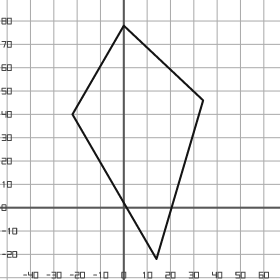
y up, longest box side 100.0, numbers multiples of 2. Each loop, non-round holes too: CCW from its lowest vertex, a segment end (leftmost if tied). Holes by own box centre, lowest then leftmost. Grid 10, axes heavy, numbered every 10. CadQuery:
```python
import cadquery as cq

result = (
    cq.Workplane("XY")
    .moveTo(14.0, -22.0)
    .lineTo(34.0, 46.0)
    .lineTo(0.0, 78.0)
    .lineTo(-22.0, 40.0)
    .close()
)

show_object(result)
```